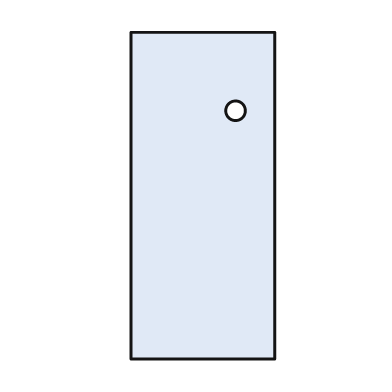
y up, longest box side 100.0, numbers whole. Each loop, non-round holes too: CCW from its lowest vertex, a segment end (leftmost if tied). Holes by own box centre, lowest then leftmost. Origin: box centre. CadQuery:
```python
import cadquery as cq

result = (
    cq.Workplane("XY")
    .moveTo(-22.0, -50.0)
    .lineTo(22.0, -50.0)
    .lineTo(22.0, 50.0)
    .lineTo(-22.0, 50.0)
    .close()
    .moveTo(10.0, 26.0)
    .circle(3.0)
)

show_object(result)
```